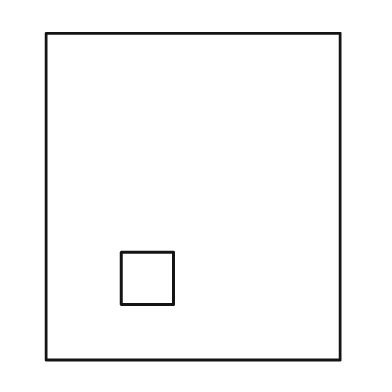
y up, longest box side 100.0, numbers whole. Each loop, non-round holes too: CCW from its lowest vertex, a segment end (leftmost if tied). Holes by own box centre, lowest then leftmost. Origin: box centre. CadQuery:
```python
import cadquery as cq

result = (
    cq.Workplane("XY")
    .moveTo(-45.0, -50.0)
    .lineTo(45.0, -50.0)
    .lineTo(45.0, 50.0)
    .lineTo(-45.0, 50.0)
    .close()
    .moveTo(-22.0, -33.0)
    .lineTo(-6.0, -33.0)
    .lineTo(-6.0, -17.0)
    .lineTo(-22.0, -17.0)
    .close()
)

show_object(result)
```